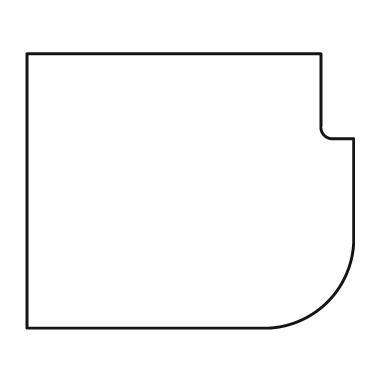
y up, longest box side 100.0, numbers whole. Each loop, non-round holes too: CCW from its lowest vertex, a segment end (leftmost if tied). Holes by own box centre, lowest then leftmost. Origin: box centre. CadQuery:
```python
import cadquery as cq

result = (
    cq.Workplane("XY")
    .moveTo(-50.0, -42.0)
    .lineTo(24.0, -42.0)
    .threePointArc((42.0, -34.0), (50.0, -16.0))
    .lineTo(50.0, 16.0)
    .lineTo(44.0, 16.0)
    .threePointArc((41.0, 17.0), (40.0, 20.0))
    .lineTo(40.0, 42.0)
    .lineTo(-50.0, 42.0)
    .close()
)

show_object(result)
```